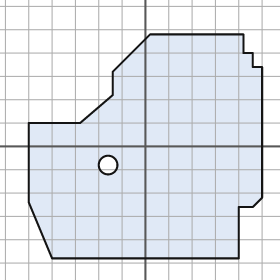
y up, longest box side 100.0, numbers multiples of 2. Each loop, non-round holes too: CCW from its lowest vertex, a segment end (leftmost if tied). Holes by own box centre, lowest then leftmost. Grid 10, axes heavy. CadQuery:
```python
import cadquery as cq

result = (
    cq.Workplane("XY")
    .moveTo(-40.0, -48.0)
    .lineTo(40.0, -48.0)
    .lineTo(40.0, -26.0)
    .lineTo(46.0, -26.0)
    .lineTo(50.0, -22.0)
    .lineTo(50.0, 34.0)
    .lineTo(46.0, 34.0)
    .lineTo(46.0, 40.0)
    .lineTo(42.0, 40.0)
    .lineTo(42.0, 48.0)
    .lineTo(2.0, 48.0)
    .lineTo(-14.0, 32.0)
    .lineTo(-14.0, 22.0)
    .lineTo(-28.0, 10.0)
    .lineTo(-50.0, 10.0)
    .lineTo(-50.0, -24.0)
    .close()
    .moveTo(-16.0, -8.0)
    .circle(4.0)
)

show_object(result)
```